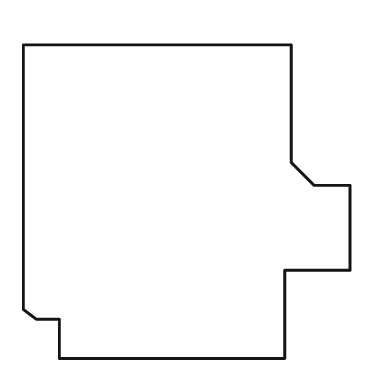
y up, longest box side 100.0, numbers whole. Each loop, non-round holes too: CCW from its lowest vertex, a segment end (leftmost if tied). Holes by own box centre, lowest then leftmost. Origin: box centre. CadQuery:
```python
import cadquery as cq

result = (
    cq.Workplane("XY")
    .moveTo(-39.0, -48.0)
    .lineTo(30.0, -48.0)
    .lineTo(30.0, -21.0)
    .lineTo(50.0, -21.0)
    .lineTo(50.0, 5.0)
    .lineTo(39.0, 5.0)
    .lineTo(32.0, 12.0)
    .lineTo(32.0, 48.0)
    .lineTo(-50.0, 48.0)
    .lineTo(-50.0, -33.0)
    .lineTo(-46.0, -36.0)
    .lineTo(-39.0, -36.0)
    .close()
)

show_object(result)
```